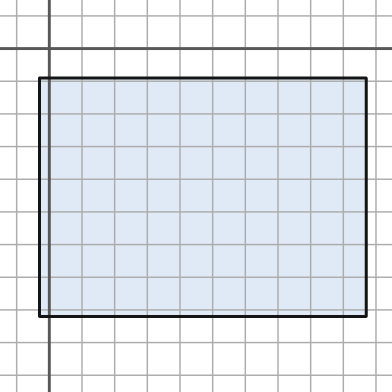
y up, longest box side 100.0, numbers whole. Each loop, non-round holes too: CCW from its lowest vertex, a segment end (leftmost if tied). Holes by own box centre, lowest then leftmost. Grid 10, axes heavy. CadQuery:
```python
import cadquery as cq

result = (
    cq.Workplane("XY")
    .moveTo(-3.0, -82.0)
    .lineTo(97.0, -82.0)
    .lineTo(97.0, -9.0)
    .lineTo(-3.0, -9.0)
    .close()
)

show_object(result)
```